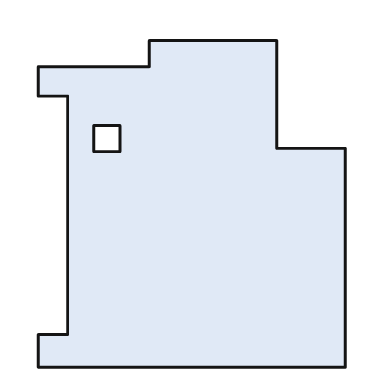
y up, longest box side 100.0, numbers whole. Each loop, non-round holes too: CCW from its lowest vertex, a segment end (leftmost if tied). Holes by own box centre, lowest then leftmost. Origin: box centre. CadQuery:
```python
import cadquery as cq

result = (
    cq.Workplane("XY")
    .moveTo(-47.0, -50.0)
    .lineTo(47.0, -50.0)
    .lineTo(47.0, 17.0)
    .lineTo(26.0, 17.0)
    .lineTo(26.0, 50.0)
    .lineTo(-13.0, 50.0)
    .lineTo(-13.0, 42.0)
    .lineTo(-47.0, 42.0)
    .lineTo(-47.0, 33.0)
    .lineTo(-38.0, 33.0)
    .lineTo(-38.0, -40.0)
    .lineTo(-47.0, -40.0)
    .close()
    .moveTo(-30.0, 16.0)
    .lineTo(-22.0, 16.0)
    .lineTo(-22.0, 24.0)
    .lineTo(-30.0, 24.0)
    .close()
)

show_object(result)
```